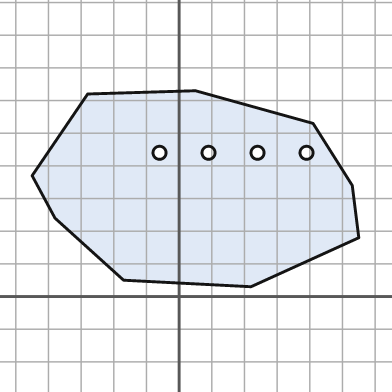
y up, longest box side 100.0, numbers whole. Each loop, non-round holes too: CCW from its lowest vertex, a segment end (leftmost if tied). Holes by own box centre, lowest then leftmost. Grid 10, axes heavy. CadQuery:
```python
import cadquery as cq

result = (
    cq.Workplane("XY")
    .moveTo(22.0, 3.0)
    .lineTo(55.0, 18.0)
    .lineTo(53.0, 34.0)
    .lineTo(41.0, 53.0)
    .lineTo(5.0, 63.0)
    .lineTo(-28.0, 62.0)
    .lineTo(-45.0, 37.0)
    .lineTo(-38.0, 24.0)
    .lineTo(-17.0, 5.0)
    .close()
    .moveTo(-6.0, 44.0)
    .circle(2.0)
    .moveTo(9.0, 44.0)
    .circle(2.0)
    .moveTo(24.0, 44.0)
    .circle(2.0)
    .moveTo(39.0, 44.0)
    .circle(2.0)
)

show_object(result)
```